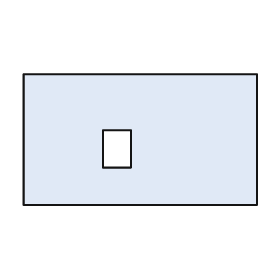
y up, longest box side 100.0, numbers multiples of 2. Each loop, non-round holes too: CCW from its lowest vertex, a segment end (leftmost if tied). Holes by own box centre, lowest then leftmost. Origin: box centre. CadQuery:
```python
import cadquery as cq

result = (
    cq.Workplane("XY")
    .moveTo(-50.0, -28.0)
    .lineTo(50.0, -28.0)
    .lineTo(50.0, 28.0)
    .lineTo(-50.0, 28.0)
    .close()
    .moveTo(-16.0, -12.0)
    .lineTo(-4.0, -12.0)
    .lineTo(-4.0, 4.0)
    .lineTo(-16.0, 4.0)
    .close()
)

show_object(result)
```